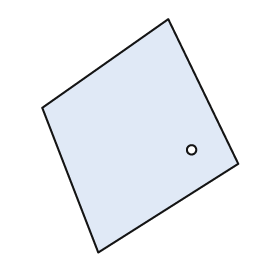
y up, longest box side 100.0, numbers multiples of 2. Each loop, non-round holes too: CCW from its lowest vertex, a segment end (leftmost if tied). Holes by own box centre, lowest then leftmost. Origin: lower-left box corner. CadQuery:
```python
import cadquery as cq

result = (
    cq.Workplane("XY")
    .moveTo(24.0, 0.0)
    .lineTo(84.0, 38.0)
    .lineTo(54.0, 100.0)
    .lineTo(0.0, 62.0)
    .close()
    .moveTo(64.0, 44.0)
    .circle(2.0)
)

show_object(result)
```